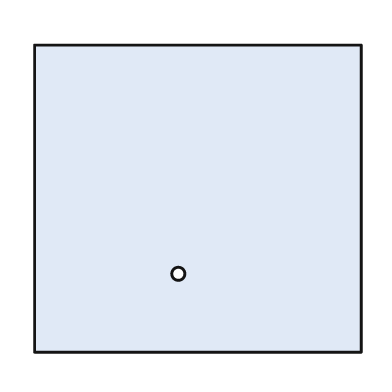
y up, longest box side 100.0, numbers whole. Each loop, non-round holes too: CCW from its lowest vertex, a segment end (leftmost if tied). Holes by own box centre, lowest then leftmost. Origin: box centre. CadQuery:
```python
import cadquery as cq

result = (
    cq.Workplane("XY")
    .moveTo(-50.0, -47.0)
    .lineTo(50.0, -47.0)
    .lineTo(50.0, 47.0)
    .lineTo(-50.0, 47.0)
    .close()
    .moveTo(-6.0, -23.0)
    .circle(2.0)
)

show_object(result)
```